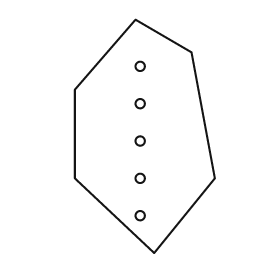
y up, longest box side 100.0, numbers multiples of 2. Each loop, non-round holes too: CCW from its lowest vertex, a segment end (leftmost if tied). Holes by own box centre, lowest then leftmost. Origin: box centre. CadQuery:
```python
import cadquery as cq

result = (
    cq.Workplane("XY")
    .moveTo(4.0, -50.0)
    .lineTo(30.0, -18.0)
    .lineTo(20.0, 36.0)
    .lineTo(-4.0, 50.0)
    .lineTo(-30.0, 20.0)
    .lineTo(-30.0, -18.0)
    .close()
    .moveTo(-2.0, -34.0)
    .circle(2.0)
    .moveTo(-2.0, -18.0)
    .circle(2.0)
    .moveTo(-2.0, -2.0)
    .circle(2.0)
    .moveTo(-2.0, 14.0)
    .circle(2.0)
    .moveTo(-2.0, 30.0)
    .circle(2.0)
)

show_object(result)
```